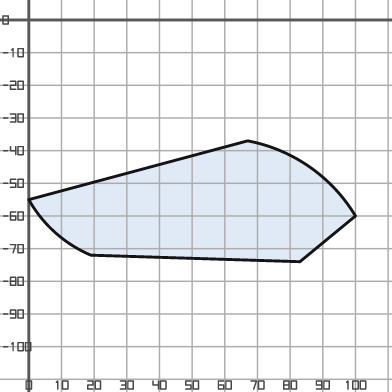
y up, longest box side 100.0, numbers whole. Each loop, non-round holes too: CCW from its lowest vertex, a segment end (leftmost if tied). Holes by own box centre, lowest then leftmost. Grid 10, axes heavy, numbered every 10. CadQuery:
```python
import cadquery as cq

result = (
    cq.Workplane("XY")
    .moveTo(83.0, -74.0)
    .lineTo(100.0, -60.0)
    .threePointArc((86.0, -45.0), (67.0, -37.0))
    .lineTo(0.0, -55.0)
    .threePointArc((8.0, -65.0), (19.0, -72.0))
    .close()
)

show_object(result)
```